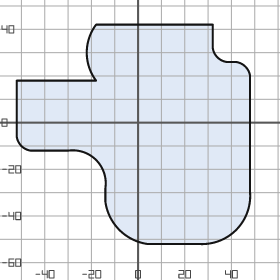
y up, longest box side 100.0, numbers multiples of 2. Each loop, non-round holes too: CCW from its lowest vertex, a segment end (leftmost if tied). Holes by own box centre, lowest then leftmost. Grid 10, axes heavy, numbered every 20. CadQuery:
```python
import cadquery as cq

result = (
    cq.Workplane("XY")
    .moveTo(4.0, -52.0)
    .lineTo(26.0, -52.0)
    .threePointArc((42.0, -46.0), (48.0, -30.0))
    .lineTo(48.0, 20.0)
    .threePointArc((46.0, 24.0), (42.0, 26.0))
    .lineTo(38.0, 26.0)
    .threePointArc((34.0, 28.0), (32.0, 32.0))
    .lineTo(32.0, 42.0)
    .lineTo(-18.0, 42.0)
    .threePointArc((-22.0, 30.0), (-18.0, 18.0))
    .lineTo(-52.0, 18.0)
    .lineTo(-52.0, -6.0)
    .threePointArc((-50.0, -10.0), (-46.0, -12.0))
    .lineTo(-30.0, -12.0)
    .threePointArc((-18.0, -16.0), (-14.0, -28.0))
    .lineTo(-14.0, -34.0)
    .threePointArc((-8.0, -46.0), (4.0, -52.0))
    .close()
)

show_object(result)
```